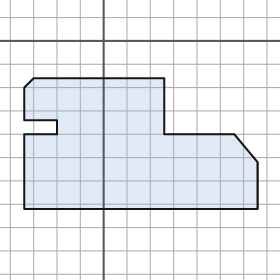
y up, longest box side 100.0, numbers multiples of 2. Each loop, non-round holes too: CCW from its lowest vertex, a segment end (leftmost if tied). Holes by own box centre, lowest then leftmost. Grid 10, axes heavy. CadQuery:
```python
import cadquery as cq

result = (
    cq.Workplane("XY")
    .moveTo(-34.0, -72.0)
    .lineTo(66.0, -72.0)
    .lineTo(66.0, -52.0)
    .lineTo(56.0, -40.0)
    .lineTo(26.0, -40.0)
    .lineTo(26.0, -16.0)
    .lineTo(-30.0, -16.0)
    .lineTo(-34.0, -20.0)
    .lineTo(-34.0, -34.0)
    .lineTo(-20.0, -34.0)
    .lineTo(-20.0, -40.0)
    .lineTo(-34.0, -40.0)
    .close()
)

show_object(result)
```